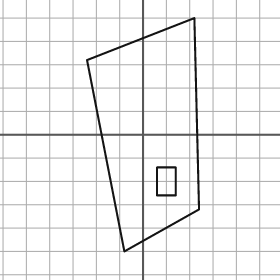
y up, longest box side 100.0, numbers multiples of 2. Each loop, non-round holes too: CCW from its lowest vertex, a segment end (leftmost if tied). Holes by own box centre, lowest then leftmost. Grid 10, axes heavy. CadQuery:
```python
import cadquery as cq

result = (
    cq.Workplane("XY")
    .moveTo(-8.0, -50.0)
    .lineTo(24.0, -32.0)
    .lineTo(22.0, 50.0)
    .lineTo(-24.0, 32.0)
    .close()
    .moveTo(6.0, -26.0)
    .lineTo(14.0, -26.0)
    .lineTo(14.0, -14.0)
    .lineTo(6.0, -14.0)
    .close()
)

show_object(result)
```